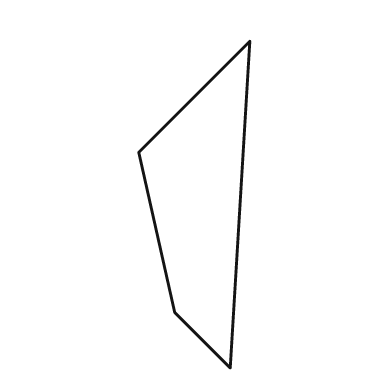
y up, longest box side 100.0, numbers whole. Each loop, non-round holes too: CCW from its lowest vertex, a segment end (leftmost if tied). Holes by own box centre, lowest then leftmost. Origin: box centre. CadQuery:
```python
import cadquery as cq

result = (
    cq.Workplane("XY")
    .moveTo(11.0, -50.0)
    .lineTo(17.0, 50.0)
    .lineTo(-17.0, 16.0)
    .lineTo(-6.0, -33.0)
    .close()
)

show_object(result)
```